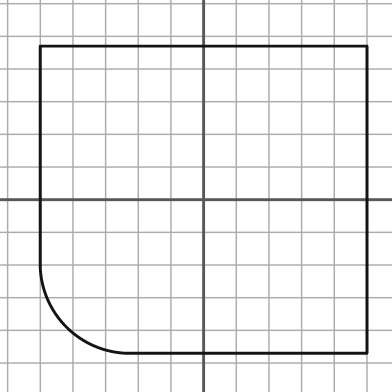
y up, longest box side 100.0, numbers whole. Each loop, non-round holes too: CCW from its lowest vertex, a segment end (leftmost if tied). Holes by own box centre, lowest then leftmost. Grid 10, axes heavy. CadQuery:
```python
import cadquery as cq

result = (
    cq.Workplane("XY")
    .moveTo(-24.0, -47.0)
    .lineTo(50.0, -47.0)
    .lineTo(50.0, 47.0)
    .lineTo(-50.0, 47.0)
    .lineTo(-50.0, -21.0)
    .threePointArc((-42.0, -39.0), (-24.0, -47.0))
    .close()
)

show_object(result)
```